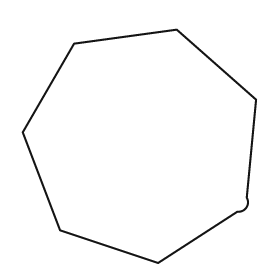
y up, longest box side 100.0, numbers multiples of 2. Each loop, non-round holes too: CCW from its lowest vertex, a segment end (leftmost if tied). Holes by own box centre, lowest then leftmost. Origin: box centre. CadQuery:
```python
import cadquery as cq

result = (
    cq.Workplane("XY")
    .moveTo(8.0, -50.0)
    .lineTo(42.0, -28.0)
    .threePointArc((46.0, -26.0), (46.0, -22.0))
    .lineTo(50.0, 20.0)
    .lineTo(16.0, 50.0)
    .lineTo(-28.0, 44.0)
    .lineTo(-50.0, 6.0)
    .lineTo(-34.0, -36.0)
    .close()
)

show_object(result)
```